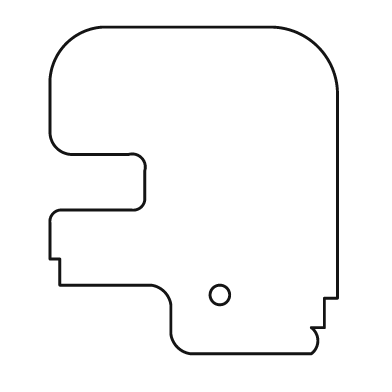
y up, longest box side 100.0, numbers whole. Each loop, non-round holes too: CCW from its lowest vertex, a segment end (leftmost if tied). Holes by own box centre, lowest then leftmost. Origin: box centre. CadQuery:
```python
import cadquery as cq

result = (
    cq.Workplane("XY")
    .moveTo(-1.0, -50.0)
    .lineTo(36.0, -50.0)
    .threePointArc((38.0, -46.0), (36.0, -42.0))
    .lineTo(40.0, -42.0)
    .lineTo(40.0, -33.0)
    .lineTo(44.0, -33.0)
    .lineTo(44.0, 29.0)
    .threePointArc((38.0, 44.0), (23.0, 50.0))
    .lineTo(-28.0, 50.0)
    .threePointArc((-39.0, 45.0), (-44.0, 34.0))
    .lineTo(-44.0, 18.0)
    .threePointArc((-42.0, 13.0), (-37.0, 11.0))
    .lineTo(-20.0, 11.0)
    .threePointArc((-16.0, 10.0), (-15.0, 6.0))
    .lineTo(-15.0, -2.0)
    .threePointArc((-16.0, -5.0), (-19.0, -6.0))
    .lineTo(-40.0, -6.0)
    .threePointArc((-43.0, -7.0), (-44.0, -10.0))
    .lineTo(-44.0, -21.0)
    .lineTo(-41.0, -21.0)
    .lineTo(-41.0, -29.0)
    .lineTo(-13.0, -29.0)
    .threePointArc((-9.0, -31.0), (-7.0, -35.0))
    .lineTo(-7.0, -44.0)
    .threePointArc((-5.0, -48.0), (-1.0, -50.0))
    .close()
    .moveTo(8.0, -32.0)
    .circle(3.0)
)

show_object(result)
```